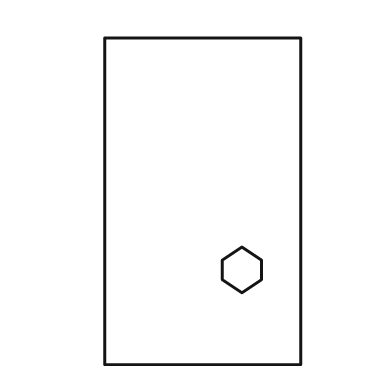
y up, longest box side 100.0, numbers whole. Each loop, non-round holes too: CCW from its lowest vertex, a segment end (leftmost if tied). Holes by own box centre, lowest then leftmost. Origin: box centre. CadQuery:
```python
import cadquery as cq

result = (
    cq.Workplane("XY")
    .moveTo(-30.0, -50.0)
    .lineTo(30.0, -50.0)
    .lineTo(30.0, 50.0)
    .lineTo(-30.0, 50.0)
    .close()
    .moveTo(12.0, -28.0)
    .lineTo(18.0, -24.0)
    .lineTo(18.0, -18.0)
    .lineTo(12.0, -14.0)
    .lineTo(6.0, -18.0)
    .lineTo(6.0, -24.0)
    .close()
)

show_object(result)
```